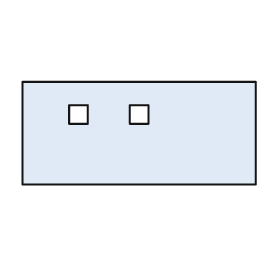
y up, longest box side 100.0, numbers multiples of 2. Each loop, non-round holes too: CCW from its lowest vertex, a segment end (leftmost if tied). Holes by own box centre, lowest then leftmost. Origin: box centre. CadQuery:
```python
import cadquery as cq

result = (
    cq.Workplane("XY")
    .moveTo(-50.0, -22.0)
    .lineTo(50.0, -22.0)
    .lineTo(50.0, 22.0)
    .lineTo(-50.0, 22.0)
    .close()
    .moveTo(-30.0, 4.0)
    .lineTo(-22.0, 4.0)
    .lineTo(-22.0, 12.0)
    .lineTo(-30.0, 12.0)
    .close()
    .moveTo(-4.0, 4.0)
    .lineTo(4.0, 4.0)
    .lineTo(4.0, 12.0)
    .lineTo(-4.0, 12.0)
    .close()
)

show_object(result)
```